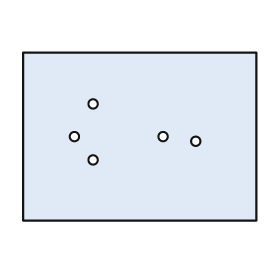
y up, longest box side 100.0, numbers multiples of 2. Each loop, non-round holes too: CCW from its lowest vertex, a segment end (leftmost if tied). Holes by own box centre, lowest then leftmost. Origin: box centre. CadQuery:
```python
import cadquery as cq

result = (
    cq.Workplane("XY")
    .moveTo(-50.0, -36.0)
    .lineTo(50.0, -36.0)
    .lineTo(50.0, 36.0)
    .lineTo(-50.0, 36.0)
    .close()
    .moveTo(-20.0, -10.0)
    .circle(2.0)
    .moveTo(24.0, -2.0)
    .circle(2.0)
    .moveTo(-28.0, 0.0)
    .circle(2.0)
    .moveTo(10.0, 0.0)
    .circle(2.0)
    .moveTo(-20.0, 14.0)
    .circle(2.0)
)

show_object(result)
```